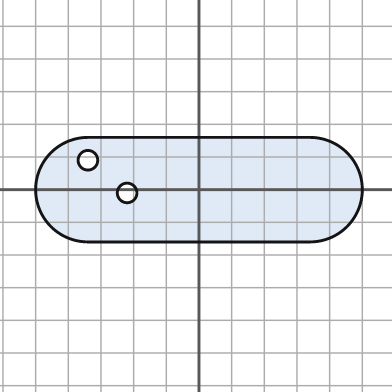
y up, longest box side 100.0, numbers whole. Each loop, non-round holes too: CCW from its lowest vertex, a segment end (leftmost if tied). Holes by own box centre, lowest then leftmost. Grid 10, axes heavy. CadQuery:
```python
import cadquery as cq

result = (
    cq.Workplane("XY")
    .moveTo(-34.0, -16.0)
    .lineTo(34.0, -16.0)
    .threePointArc((50.0, 0.0), (34.0, 16.0))
    .lineTo(-34.0, 16.0)
    .threePointArc((-50.0, 0.0), (-34.0, -16.0))
    .close()
    .moveTo(-22.0, -1.0)
    .circle(3.0)
    .moveTo(-34.0, 9.0)
    .circle(3.0)
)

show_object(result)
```